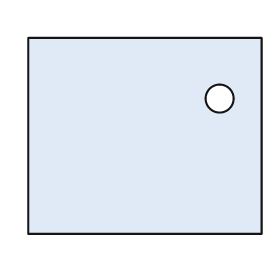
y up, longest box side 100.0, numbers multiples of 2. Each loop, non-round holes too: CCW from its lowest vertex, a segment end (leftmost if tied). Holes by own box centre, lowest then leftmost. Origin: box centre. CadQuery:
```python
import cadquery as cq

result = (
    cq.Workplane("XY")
    .moveTo(-50.0, -42.0)
    .lineTo(50.0, -42.0)
    .lineTo(50.0, 42.0)
    .lineTo(-50.0, 42.0)
    .close()
    .moveTo(32.0, 16.0)
    .circle(6.0)
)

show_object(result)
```